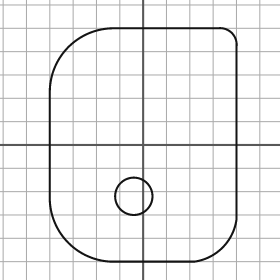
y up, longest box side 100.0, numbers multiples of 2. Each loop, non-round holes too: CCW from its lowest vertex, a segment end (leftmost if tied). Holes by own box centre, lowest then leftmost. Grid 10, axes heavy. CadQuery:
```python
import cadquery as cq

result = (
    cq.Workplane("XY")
    .moveTo(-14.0, -50.0)
    .lineTo(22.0, -50.0)
    .threePointArc((34.0, -44.0), (40.0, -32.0))
    .lineTo(40.0, 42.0)
    .threePointArc((38.0, 48.0), (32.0, 50.0))
    .lineTo(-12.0, 50.0)
    .threePointArc((-32.0, 42.0), (-40.0, 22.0))
    .lineTo(-40.0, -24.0)
    .threePointArc((-32.0, -42.0), (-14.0, -50.0))
    .close()
    .moveTo(-4.0, -22.0)
    .circle(8.0)
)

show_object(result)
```